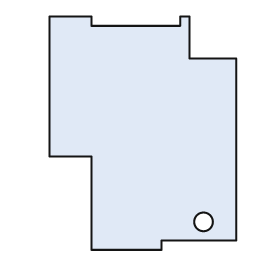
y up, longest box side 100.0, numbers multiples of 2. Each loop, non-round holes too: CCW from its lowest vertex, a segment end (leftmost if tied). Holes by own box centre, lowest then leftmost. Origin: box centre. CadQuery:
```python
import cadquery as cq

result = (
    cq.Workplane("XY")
    .moveTo(-22.0, -50.0)
    .lineTo(8.0, -50.0)
    .lineTo(8.0, -46.0)
    .lineTo(40.0, -46.0)
    .lineTo(40.0, 32.0)
    .lineTo(20.0, 32.0)
    .lineTo(20.0, 50.0)
    .lineTo(16.0, 50.0)
    .lineTo(16.0, 46.0)
    .lineTo(-22.0, 46.0)
    .lineTo(-22.0, 50.0)
    .lineTo(-40.0, 50.0)
    .lineTo(-40.0, -10.0)
    .lineTo(-22.0, -10.0)
    .close()
    .moveTo(26.0, -38.0)
    .circle(4.0)
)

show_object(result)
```